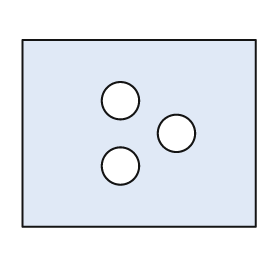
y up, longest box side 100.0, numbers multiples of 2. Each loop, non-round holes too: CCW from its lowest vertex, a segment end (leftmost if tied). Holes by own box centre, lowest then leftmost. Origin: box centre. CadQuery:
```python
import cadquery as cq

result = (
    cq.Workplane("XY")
    .moveTo(-50.0, -40.0)
    .lineTo(50.0, -40.0)
    .lineTo(50.0, 40.0)
    .lineTo(-50.0, 40.0)
    .close()
    .moveTo(-8.0, -14.0)
    .circle(8.0)
    .moveTo(16.0, 0.0)
    .circle(8.0)
    .moveTo(-8.0, 14.0)
    .circle(8.0)
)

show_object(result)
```